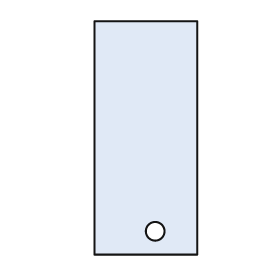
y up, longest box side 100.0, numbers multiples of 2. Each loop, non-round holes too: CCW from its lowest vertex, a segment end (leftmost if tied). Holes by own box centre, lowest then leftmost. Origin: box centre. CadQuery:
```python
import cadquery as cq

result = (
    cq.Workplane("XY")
    .moveTo(-22.0, -50.0)
    .lineTo(22.0, -50.0)
    .lineTo(22.0, 50.0)
    .lineTo(-22.0, 50.0)
    .close()
    .moveTo(4.0, -40.0)
    .circle(4.0)
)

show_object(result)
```